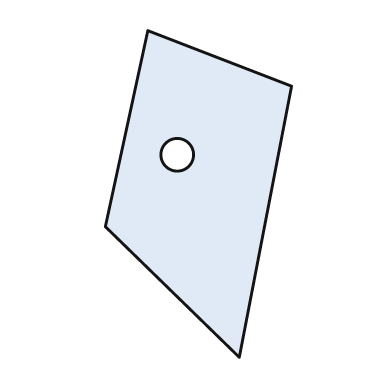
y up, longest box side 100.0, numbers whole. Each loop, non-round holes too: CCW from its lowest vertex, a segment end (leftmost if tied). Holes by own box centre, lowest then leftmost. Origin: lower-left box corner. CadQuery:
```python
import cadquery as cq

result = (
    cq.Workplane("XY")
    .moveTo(41.0, 0.0)
    .lineTo(57.0, 83.0)
    .lineTo(13.0, 100.0)
    .lineTo(0.0, 40.0)
    .close()
    .moveTo(22.0, 62.0)
    .circle(5.0)
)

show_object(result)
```